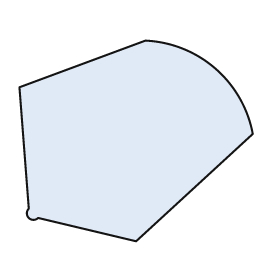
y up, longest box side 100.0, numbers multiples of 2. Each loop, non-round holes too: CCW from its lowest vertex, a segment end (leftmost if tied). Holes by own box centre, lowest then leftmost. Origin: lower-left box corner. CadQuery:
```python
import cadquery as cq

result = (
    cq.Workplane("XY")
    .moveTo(50.0, 0.0)
    .lineTo(100.0, 46.0)
    .threePointArc((84.0, 74.0), (54.0, 86.0))
    .lineTo(0.0, 66.0)
    .lineTo(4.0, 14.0)
    .threePointArc((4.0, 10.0), (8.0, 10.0))
    .close()
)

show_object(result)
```